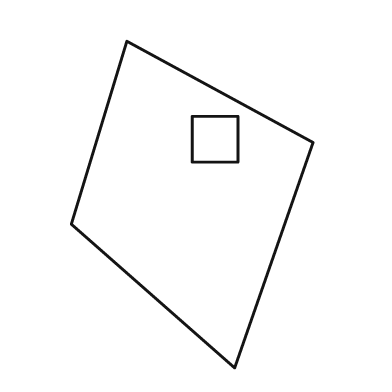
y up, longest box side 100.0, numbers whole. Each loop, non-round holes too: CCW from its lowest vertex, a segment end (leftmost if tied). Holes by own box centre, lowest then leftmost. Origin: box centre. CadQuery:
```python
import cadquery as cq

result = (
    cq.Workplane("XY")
    .moveTo(13.0, -50.0)
    .lineTo(37.0, 19.0)
    .lineTo(-20.0, 50.0)
    .lineTo(-37.0, -6.0)
    .close()
    .moveTo(0.0, 13.0)
    .lineTo(14.0, 13.0)
    .lineTo(14.0, 27.0)
    .lineTo(0.0, 27.0)
    .close()
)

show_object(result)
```